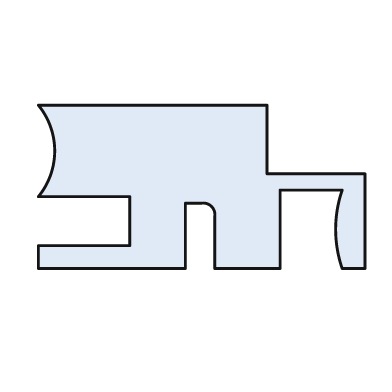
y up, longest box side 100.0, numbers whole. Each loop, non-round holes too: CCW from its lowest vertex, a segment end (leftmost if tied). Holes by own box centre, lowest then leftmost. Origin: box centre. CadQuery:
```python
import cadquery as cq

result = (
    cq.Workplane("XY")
    .moveTo(-50.0, -25.0)
    .lineTo(-5.0, -25.0)
    .lineTo(-5.0, -5.0)
    .lineTo(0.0, -5.0)
    .threePointArc((3.0, -6.0), (4.0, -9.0))
    .lineTo(4.0, -25.0)
    .lineTo(24.0, -25.0)
    .lineTo(24.0, -1.0)
    .lineTo(43.0, -1.0)
    .threePointArc((41.0, -13.0), (43.0, -25.0))
    .lineTo(50.0, -25.0)
    .lineTo(50.0, 4.0)
    .lineTo(20.0, 4.0)
    .lineTo(20.0, 25.0)
    .lineTo(-50.0, 25.0)
    .threePointArc((-45.0, 11.0), (-50.0, -3.0))
    .lineTo(-22.0, -3.0)
    .lineTo(-22.0, -18.0)
    .lineTo(-50.0, -18.0)
    .close()
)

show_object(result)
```